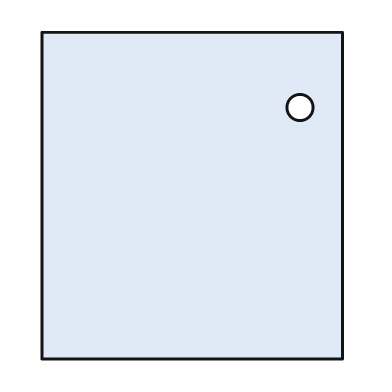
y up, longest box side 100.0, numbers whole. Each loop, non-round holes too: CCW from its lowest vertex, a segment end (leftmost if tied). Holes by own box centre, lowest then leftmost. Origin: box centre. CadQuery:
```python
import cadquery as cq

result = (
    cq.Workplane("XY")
    .moveTo(-46.0, -50.0)
    .lineTo(46.0, -50.0)
    .lineTo(46.0, 50.0)
    .lineTo(-46.0, 50.0)
    .close()
    .moveTo(33.0, 27.0)
    .circle(4.0)
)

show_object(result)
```